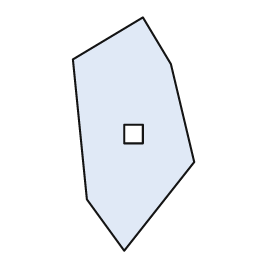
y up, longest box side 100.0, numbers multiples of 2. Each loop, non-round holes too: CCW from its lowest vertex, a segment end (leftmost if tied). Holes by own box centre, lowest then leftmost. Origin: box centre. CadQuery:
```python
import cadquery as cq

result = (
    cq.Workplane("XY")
    .moveTo(-4.0, -50.0)
    .lineTo(26.0, -12.0)
    .lineTo(16.0, 30.0)
    .lineTo(4.0, 50.0)
    .lineTo(-26.0, 32.0)
    .lineTo(-20.0, -28.0)
    .close()
    .moveTo(-4.0, -4.0)
    .lineTo(4.0, -4.0)
    .lineTo(4.0, 4.0)
    .lineTo(-4.0, 4.0)
    .close()
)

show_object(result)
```